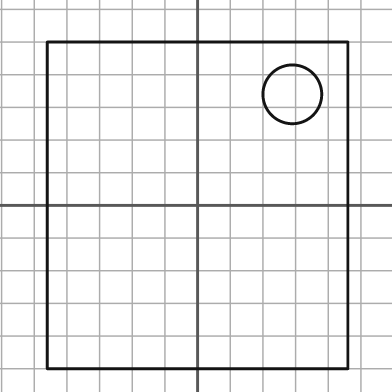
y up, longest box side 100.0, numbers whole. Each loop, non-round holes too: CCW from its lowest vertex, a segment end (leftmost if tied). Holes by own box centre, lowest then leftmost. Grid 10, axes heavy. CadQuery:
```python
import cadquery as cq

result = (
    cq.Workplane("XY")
    .moveTo(-46.0, -50.0)
    .lineTo(46.0, -50.0)
    .lineTo(46.0, 50.0)
    .lineTo(-46.0, 50.0)
    .close()
    .moveTo(29.0, 34.0)
    .circle(9.0)
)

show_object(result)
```